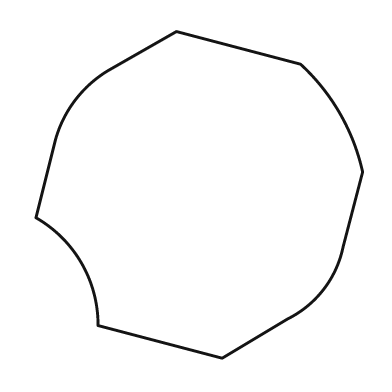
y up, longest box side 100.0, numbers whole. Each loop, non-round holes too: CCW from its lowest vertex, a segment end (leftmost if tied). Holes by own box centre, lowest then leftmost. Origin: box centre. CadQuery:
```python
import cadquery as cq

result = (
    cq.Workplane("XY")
    .moveTo(7.0, -50.0)
    .lineTo(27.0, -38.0)
    .threePointArc((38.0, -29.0), (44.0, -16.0))
    .lineTo(50.0, 7.0)
    .threePointArc((43.0, 25.0), (31.0, 40.0))
    .lineTo(-7.0, 50.0)
    .lineTo(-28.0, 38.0)
    .threePointArc((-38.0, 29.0), (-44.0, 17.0))
    .lineTo(-50.0, -7.0)
    .threePointArc((-36.0, -21.0), (-31.0, -40.0))
    .close()
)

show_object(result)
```